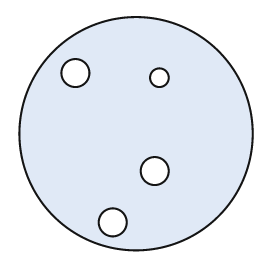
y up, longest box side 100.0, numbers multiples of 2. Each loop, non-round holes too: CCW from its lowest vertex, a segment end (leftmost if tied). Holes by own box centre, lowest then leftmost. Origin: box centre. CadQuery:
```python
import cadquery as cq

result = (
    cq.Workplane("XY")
    .moveTo(0.0, 0.0)
    .circle(50.0)
    .moveTo(-10.0, -38.0)
    .circle(6.0)
    .moveTo(8.0, -16.0)
    .circle(6.0)
    .moveTo(10.0, 24.0)
    .circle(4.0)
    .moveTo(-26.0, 26.0)
    .circle(6.0)
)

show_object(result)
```